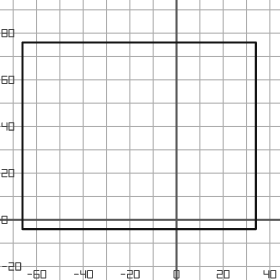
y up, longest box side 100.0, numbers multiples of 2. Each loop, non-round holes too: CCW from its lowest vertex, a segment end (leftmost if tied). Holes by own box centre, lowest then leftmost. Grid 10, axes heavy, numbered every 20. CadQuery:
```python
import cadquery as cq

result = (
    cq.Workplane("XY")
    .moveTo(-66.0, -4.0)
    .lineTo(34.0, -4.0)
    .lineTo(34.0, 76.0)
    .lineTo(-66.0, 76.0)
    .close()
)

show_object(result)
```